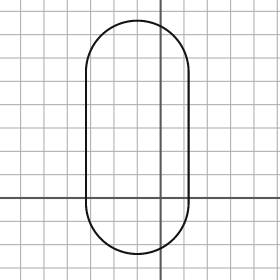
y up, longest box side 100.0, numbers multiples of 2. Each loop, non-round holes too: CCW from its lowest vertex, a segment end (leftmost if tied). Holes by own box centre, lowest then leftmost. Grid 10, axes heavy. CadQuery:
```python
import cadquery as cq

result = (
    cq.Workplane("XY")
    .moveTo(-32.0, -2.0)
    .threePointArc((-10.0, -24.0), (12.0, -2.0))
    .lineTo(12.0, 54.0)
    .threePointArc((-10.0, 76.0), (-32.0, 54.0))
    .close()
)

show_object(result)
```